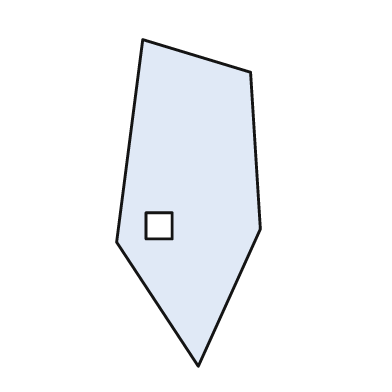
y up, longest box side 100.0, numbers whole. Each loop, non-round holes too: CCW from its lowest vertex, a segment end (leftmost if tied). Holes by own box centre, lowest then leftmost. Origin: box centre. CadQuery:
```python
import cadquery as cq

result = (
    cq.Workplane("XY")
    .moveTo(3.0, -50.0)
    .lineTo(22.0, -8.0)
    .lineTo(19.0, 40.0)
    .lineTo(-14.0, 50.0)
    .lineTo(-22.0, -12.0)
    .close()
    .moveTo(-13.0, -11.0)
    .lineTo(-5.0, -11.0)
    .lineTo(-5.0, -3.0)
    .lineTo(-13.0, -3.0)
    .close()
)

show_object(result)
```